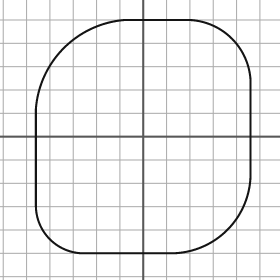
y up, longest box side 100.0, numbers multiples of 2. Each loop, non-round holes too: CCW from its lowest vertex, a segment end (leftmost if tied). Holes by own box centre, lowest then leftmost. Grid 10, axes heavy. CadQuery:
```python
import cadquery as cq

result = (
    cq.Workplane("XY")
    .moveTo(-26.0, -50.0)
    .lineTo(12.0, -50.0)
    .threePointArc((36.0, -40.0), (46.0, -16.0))
    .lineTo(46.0, 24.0)
    .threePointArc((38.0, 42.0), (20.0, 50.0))
    .lineTo(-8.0, 50.0)
    .threePointArc((-34.0, 38.0), (-46.0, 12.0))
    .lineTo(-46.0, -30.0)
    .threePointArc((-40.0, -44.0), (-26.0, -50.0))
    .close()
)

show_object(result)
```